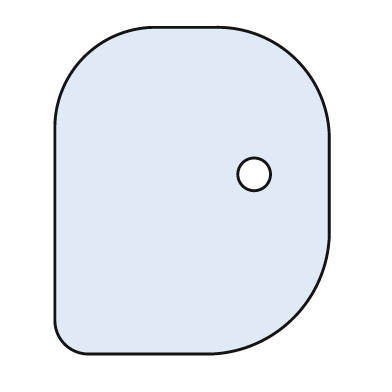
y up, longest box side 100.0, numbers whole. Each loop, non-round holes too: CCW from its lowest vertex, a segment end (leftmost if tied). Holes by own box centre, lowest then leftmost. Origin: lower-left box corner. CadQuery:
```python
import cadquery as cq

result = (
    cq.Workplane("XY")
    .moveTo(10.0, 0.0)
    .lineTo(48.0, 0.0)
    .threePointArc((73.0, 11.0), (84.0, 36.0))
    .lineTo(84.0, 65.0)
    .threePointArc((74.0, 90.0), (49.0, 100.0))
    .lineTo(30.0, 100.0)
    .threePointArc((9.0, 91.0), (0.0, 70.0))
    .lineTo(0.0, 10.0)
    .threePointArc((3.0, 3.0), (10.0, 0.0))
    .close()
    .moveTo(61.0, 55.0)
    .circle(5.0)
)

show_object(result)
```